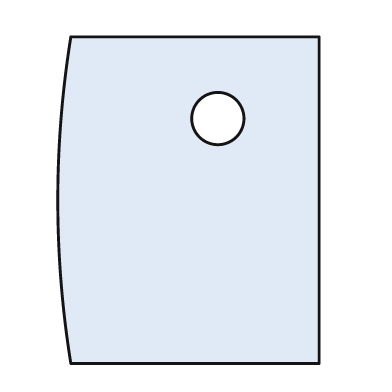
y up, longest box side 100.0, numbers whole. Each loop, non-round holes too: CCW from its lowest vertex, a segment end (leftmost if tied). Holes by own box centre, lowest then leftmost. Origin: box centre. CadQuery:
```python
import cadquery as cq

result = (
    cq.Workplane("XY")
    .moveTo(-36.0, -50.0)
    .lineTo(40.0, -50.0)
    .lineTo(40.0, 50.0)
    .lineTo(-36.0, 50.0)
    .threePointArc((-40.0, 0.0), (-36.0, -50.0))
    .close()
    .moveTo(9.0, 25.0)
    .circle(8.0)
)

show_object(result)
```